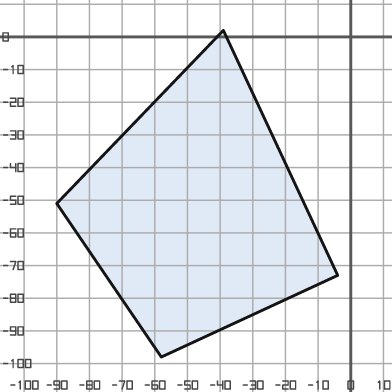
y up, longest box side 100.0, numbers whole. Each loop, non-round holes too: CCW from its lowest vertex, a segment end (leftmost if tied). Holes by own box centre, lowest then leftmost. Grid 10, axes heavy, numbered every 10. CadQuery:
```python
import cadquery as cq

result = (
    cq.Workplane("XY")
    .moveTo(-58.0, -98.0)
    .lineTo(-4.0, -73.0)
    .lineTo(-39.0, 2.0)
    .lineTo(-90.0, -51.0)
    .close()
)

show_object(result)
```